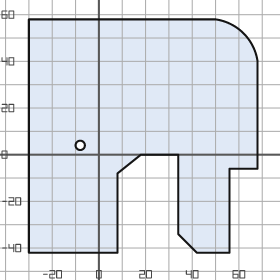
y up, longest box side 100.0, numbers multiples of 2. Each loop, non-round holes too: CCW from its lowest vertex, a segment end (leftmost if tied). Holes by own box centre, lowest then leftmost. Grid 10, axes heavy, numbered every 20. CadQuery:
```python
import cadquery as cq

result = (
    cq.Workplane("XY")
    .moveTo(-30.0, -42.0)
    .lineTo(8.0, -42.0)
    .lineTo(8.0, -8.0)
    .lineTo(18.0, 0.0)
    .lineTo(34.0, 0.0)
    .lineTo(34.0, -34.0)
    .lineTo(42.0, -42.0)
    .lineTo(56.0, -42.0)
    .lineTo(56.0, -6.0)
    .lineTo(68.0, -6.0)
    .lineTo(68.0, 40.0)
    .threePointArc((62.0, 52.0), (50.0, 58.0))
    .lineTo(-30.0, 58.0)
    .close()
    .moveTo(-8.0, 4.0)
    .circle(2.0)
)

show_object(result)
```